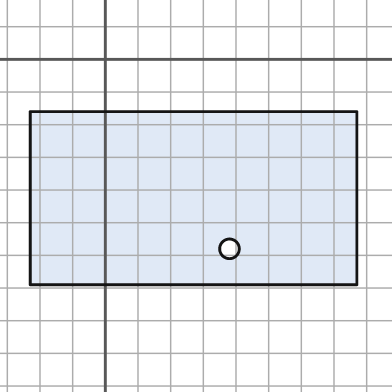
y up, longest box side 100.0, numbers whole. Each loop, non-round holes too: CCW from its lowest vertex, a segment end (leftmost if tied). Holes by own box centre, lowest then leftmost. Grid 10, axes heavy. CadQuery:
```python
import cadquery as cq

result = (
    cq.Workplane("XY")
    .moveTo(-23.0, -69.0)
    .lineTo(77.0, -69.0)
    .lineTo(77.0, -16.0)
    .lineTo(-23.0, -16.0)
    .close()
    .moveTo(38.0, -58.0)
    .circle(3.0)
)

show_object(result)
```